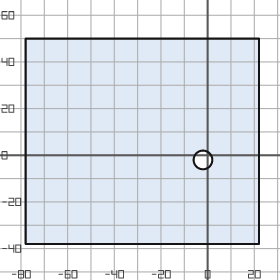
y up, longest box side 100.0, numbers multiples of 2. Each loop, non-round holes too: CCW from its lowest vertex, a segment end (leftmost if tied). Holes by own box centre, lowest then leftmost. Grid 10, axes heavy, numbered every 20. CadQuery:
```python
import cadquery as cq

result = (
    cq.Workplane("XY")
    .moveTo(-78.0, -38.0)
    .lineTo(22.0, -38.0)
    .lineTo(22.0, 50.0)
    .lineTo(-78.0, 50.0)
    .close()
    .moveTo(-2.0, -2.0)
    .circle(4.0)
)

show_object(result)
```